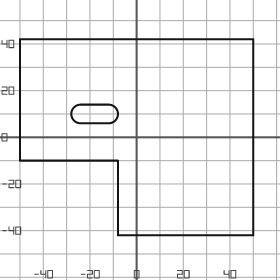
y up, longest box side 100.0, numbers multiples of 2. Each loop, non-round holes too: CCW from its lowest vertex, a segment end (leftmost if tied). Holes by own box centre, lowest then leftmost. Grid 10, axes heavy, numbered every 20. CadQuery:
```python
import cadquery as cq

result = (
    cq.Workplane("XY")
    .moveTo(-8.0, -42.0)
    .lineTo(50.0, -42.0)
    .lineTo(50.0, 42.0)
    .lineTo(-50.0, 42.0)
    .lineTo(-50.0, -10.0)
    .lineTo(-8.0, -10.0)
    .close()
    .moveTo(-24.0, 6.0)
    .lineTo(-12.0, 6.0)
    .threePointArc((-8.0, 10.0), (-12.0, 14.0))
    .lineTo(-24.0, 14.0)
    .threePointArc((-28.0, 10.0), (-24.0, 6.0))
    .close()
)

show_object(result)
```